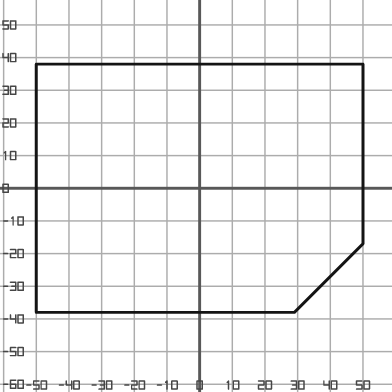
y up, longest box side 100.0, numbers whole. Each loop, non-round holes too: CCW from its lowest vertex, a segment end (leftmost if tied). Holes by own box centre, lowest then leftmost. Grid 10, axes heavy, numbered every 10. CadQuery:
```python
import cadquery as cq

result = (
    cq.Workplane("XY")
    .moveTo(-50.0, -38.0)
    .lineTo(29.0, -38.0)
    .lineTo(50.0, -17.0)
    .lineTo(50.0, 38.0)
    .lineTo(-50.0, 38.0)
    .close()
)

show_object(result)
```